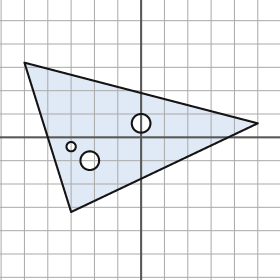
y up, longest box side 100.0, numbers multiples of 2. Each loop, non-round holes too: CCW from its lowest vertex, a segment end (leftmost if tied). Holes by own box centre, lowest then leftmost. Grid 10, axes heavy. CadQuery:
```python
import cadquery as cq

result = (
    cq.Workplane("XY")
    .moveTo(-30.0, -32.0)
    .lineTo(50.0, 6.0)
    .lineTo(-50.0, 32.0)
    .close()
    .moveTo(-22.0, -10.0)
    .circle(4.0)
    .moveTo(-30.0, -4.0)
    .circle(2.0)
    .moveTo(0.0, 6.0)
    .circle(4.0)
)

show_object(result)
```